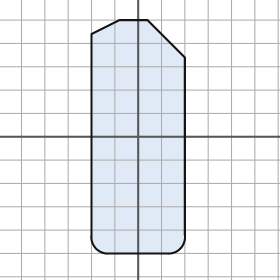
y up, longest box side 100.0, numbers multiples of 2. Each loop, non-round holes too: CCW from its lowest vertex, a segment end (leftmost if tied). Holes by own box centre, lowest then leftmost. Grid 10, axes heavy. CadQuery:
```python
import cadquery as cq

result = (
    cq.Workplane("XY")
    .moveTo(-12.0, -50.0)
    .lineTo(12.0, -50.0)
    .threePointArc((18.0, -48.0), (20.0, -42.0))
    .lineTo(20.0, 34.0)
    .lineTo(4.0, 50.0)
    .lineTo(-8.0, 50.0)
    .lineTo(-20.0, 44.0)
    .lineTo(-20.0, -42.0)
    .threePointArc((-18.0, -48.0), (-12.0, -50.0))
    .close()
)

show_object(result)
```